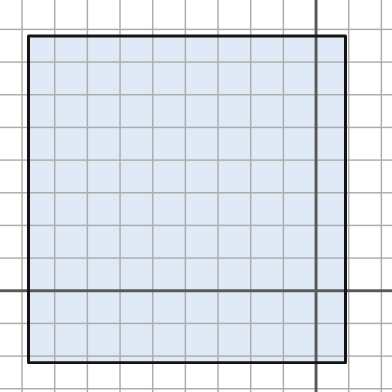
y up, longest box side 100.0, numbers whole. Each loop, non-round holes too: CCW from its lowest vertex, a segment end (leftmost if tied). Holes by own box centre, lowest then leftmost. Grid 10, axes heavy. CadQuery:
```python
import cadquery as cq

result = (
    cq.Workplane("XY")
    .moveTo(-88.0, -22.0)
    .lineTo(9.0, -22.0)
    .lineTo(9.0, 78.0)
    .lineTo(-88.0, 78.0)
    .close()
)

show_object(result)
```